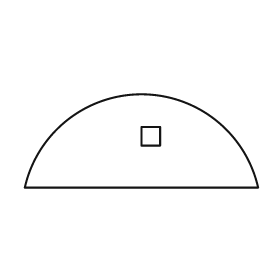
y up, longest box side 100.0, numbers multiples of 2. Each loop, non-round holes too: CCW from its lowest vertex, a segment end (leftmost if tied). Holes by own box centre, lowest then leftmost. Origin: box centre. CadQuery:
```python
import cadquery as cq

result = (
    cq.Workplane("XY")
    .moveTo(-50.0, -20.0)
    .lineTo(50.0, -20.0)
    .threePointArc((0.0, 20.0), (-50.0, -20.0))
    .close()
    .moveTo(0.0, -2.0)
    .lineTo(8.0, -2.0)
    .lineTo(8.0, 6.0)
    .lineTo(0.0, 6.0)
    .close()
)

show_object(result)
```